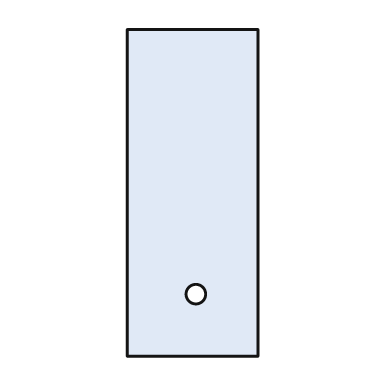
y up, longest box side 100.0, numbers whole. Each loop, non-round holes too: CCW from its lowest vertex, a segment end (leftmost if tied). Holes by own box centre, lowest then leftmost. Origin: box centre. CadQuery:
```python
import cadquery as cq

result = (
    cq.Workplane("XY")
    .moveTo(-20.0, -50.0)
    .lineTo(20.0, -50.0)
    .lineTo(20.0, 50.0)
    .lineTo(-20.0, 50.0)
    .close()
    .moveTo(1.0, -31.0)
    .circle(3.0)
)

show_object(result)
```